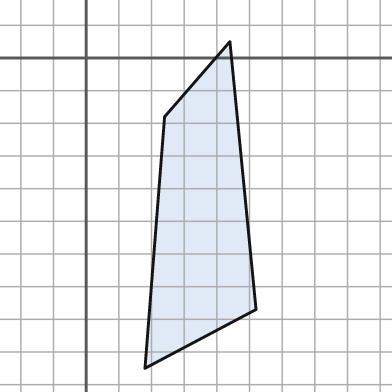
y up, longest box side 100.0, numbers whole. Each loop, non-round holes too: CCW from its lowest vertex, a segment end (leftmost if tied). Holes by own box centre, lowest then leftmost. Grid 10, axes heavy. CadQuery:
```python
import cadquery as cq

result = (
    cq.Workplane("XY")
    .moveTo(18.0, -95.0)
    .lineTo(52.0, -77.0)
    .lineTo(44.0, 5.0)
    .lineTo(24.0, -18.0)
    .close()
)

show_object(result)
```